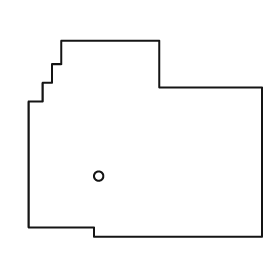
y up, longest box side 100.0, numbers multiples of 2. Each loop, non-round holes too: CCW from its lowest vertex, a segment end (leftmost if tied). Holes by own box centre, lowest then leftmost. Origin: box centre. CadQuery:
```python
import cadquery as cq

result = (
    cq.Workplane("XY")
    .moveTo(-22.0, -42.0)
    .lineTo(50.0, -42.0)
    .lineTo(50.0, 22.0)
    .lineTo(6.0, 22.0)
    .lineTo(6.0, 42.0)
    .lineTo(-36.0, 42.0)
    .lineTo(-36.0, 32.0)
    .lineTo(-40.0, 32.0)
    .lineTo(-40.0, 24.0)
    .lineTo(-44.0, 24.0)
    .lineTo(-44.0, 16.0)
    .lineTo(-50.0, 16.0)
    .lineTo(-50.0, -38.0)
    .lineTo(-22.0, -38.0)
    .close()
    .moveTo(-20.0, -16.0)
    .circle(2.0)
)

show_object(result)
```